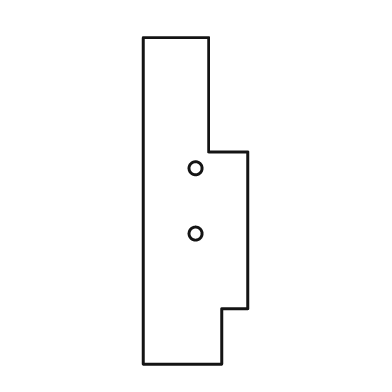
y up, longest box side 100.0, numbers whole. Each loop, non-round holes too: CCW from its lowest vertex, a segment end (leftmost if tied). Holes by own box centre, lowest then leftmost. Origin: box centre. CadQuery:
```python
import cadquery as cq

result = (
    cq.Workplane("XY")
    .moveTo(-16.0, -50.0)
    .lineTo(8.0, -50.0)
    .lineTo(8.0, -33.0)
    .lineTo(16.0, -33.0)
    .lineTo(16.0, 15.0)
    .lineTo(4.0, 15.0)
    .lineTo(4.0, 50.0)
    .lineTo(-16.0, 50.0)
    .close()
    .moveTo(0.0, -10.0)
    .circle(2.0)
    .moveTo(0.0, 10.0)
    .circle(2.0)
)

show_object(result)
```